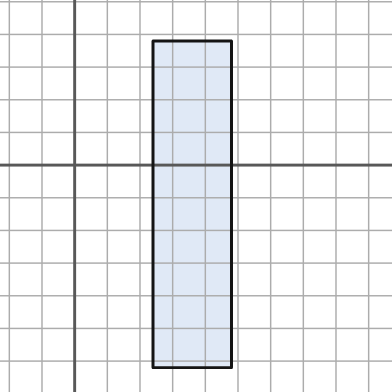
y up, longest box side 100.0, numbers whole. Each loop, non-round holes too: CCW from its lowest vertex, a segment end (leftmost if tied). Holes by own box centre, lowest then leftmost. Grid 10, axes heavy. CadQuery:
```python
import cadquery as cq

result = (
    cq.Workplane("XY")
    .moveTo(24.0, -62.0)
    .lineTo(48.0, -62.0)
    .lineTo(48.0, 38.0)
    .lineTo(24.0, 38.0)
    .close()
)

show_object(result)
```